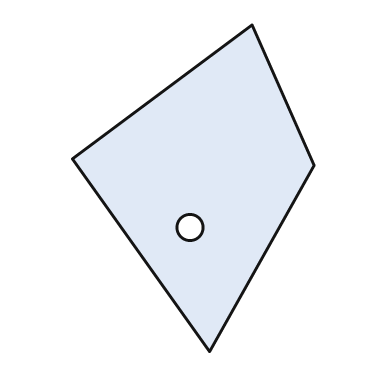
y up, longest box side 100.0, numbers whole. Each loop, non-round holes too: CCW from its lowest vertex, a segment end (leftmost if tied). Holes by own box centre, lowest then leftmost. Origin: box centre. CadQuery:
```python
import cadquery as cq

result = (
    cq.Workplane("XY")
    .moveTo(5.0, -50.0)
    .lineTo(37.0, 7.0)
    .lineTo(18.0, 50.0)
    .lineTo(-37.0, 9.0)
    .close()
    .moveTo(-1.0, -12.0)
    .circle(4.0)
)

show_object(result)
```